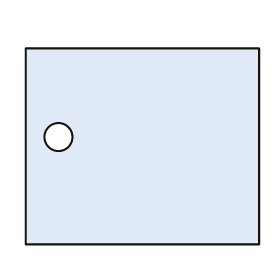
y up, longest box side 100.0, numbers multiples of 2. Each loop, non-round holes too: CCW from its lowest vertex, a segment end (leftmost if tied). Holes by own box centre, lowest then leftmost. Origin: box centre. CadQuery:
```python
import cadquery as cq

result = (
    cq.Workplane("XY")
    .moveTo(-50.0, -42.0)
    .lineTo(50.0, -42.0)
    .lineTo(50.0, 42.0)
    .lineTo(-50.0, 42.0)
    .close()
    .moveTo(-36.0, 4.0)
    .circle(6.0)
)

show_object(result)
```